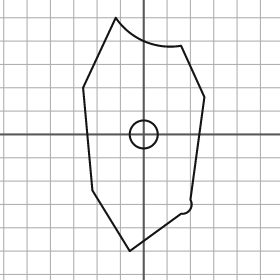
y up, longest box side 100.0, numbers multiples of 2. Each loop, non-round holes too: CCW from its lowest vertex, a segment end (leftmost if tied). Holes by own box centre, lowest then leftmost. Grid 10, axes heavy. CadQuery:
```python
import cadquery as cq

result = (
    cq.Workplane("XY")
    .moveTo(-6.0, -50.0)
    .lineTo(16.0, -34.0)
    .threePointArc((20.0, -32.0), (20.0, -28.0))
    .lineTo(26.0, 16.0)
    .lineTo(16.0, 38.0)
    .threePointArc((0.0, 40.0), (-12.0, 50.0))
    .lineTo(-26.0, 20.0)
    .lineTo(-22.0, -24.0)
    .close()
    .moveTo(0.0, 0.0)
    .circle(6.0)
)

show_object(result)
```